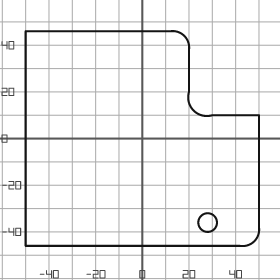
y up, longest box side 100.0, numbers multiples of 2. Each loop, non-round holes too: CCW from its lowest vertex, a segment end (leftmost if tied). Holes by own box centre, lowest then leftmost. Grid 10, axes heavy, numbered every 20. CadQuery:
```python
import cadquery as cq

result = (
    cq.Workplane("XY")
    .moveTo(-50.0, -46.0)
    .lineTo(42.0, -46.0)
    .threePointArc((48.0, -44.0), (50.0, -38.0))
    .lineTo(50.0, 10.0)
    .lineTo(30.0, 10.0)
    .threePointArc((22.0, 12.0), (20.0, 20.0))
    .lineTo(20.0, 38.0)
    .threePointArc((18.0, 44.0), (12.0, 46.0))
    .lineTo(-50.0, 46.0)
    .close()
    .moveTo(28.0, -36.0)
    .circle(4.0)
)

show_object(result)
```